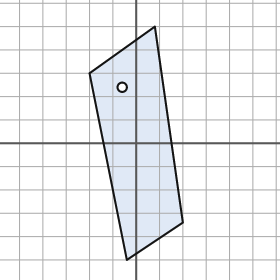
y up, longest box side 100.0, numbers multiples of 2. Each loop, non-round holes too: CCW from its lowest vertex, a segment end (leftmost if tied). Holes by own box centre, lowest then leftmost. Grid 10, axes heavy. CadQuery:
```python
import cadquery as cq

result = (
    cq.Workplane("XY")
    .moveTo(-4.0, -50.0)
    .lineTo(20.0, -34.0)
    .lineTo(8.0, 50.0)
    .lineTo(-20.0, 30.0)
    .close()
    .moveTo(-6.0, 24.0)
    .circle(2.0)
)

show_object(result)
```